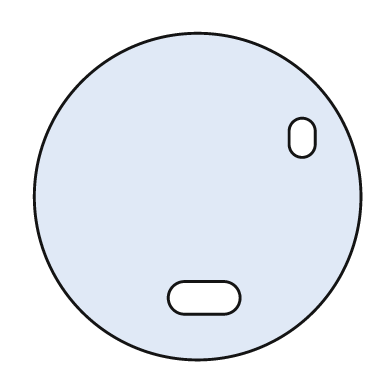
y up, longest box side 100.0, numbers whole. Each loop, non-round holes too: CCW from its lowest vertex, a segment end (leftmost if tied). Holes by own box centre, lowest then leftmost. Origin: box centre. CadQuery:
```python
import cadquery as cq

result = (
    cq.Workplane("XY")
    .moveTo(0.0, 0.0)
    .circle(50.0)
    .moveTo(-4.0, -36.0)
    .lineTo(8.0, -36.0)
    .threePointArc((13.0, -31.0), (8.0, -26.0))
    .lineTo(-4.0, -26.0)
    .threePointArc((-9.0, -31.0), (-4.0, -36.0))
    .close()
    .moveTo(28.0, 16.0)
    .threePointArc((32.0, 12.0), (36.0, 16.0))
    .lineTo(36.0, 20.0)
    .threePointArc((32.0, 24.0), (28.0, 20.0))
    .close()
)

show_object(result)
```